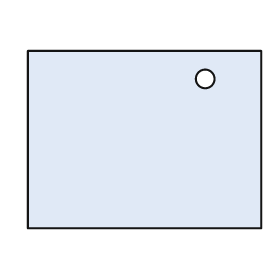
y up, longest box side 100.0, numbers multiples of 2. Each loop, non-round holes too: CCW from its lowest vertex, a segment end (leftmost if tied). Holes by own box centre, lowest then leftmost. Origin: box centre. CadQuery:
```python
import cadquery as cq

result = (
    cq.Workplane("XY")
    .moveTo(-50.0, -38.0)
    .lineTo(50.0, -38.0)
    .lineTo(50.0, 38.0)
    .lineTo(-50.0, 38.0)
    .close()
    .moveTo(26.0, 26.0)
    .circle(4.0)
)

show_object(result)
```